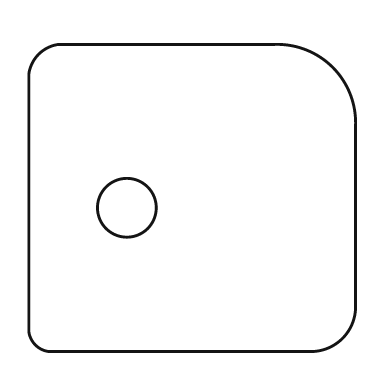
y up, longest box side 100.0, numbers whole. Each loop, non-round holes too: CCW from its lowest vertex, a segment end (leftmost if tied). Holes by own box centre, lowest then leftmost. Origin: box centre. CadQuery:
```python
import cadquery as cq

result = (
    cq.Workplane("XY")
    .moveTo(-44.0, -47.0)
    .lineTo(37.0, -47.0)
    .threePointArc((46.0, -43.0), (50.0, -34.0))
    .lineTo(50.0, 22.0)
    .threePointArc((43.0, 40.0), (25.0, 47.0))
    .lineTo(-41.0, 47.0)
    .threePointArc((-47.0, 44.0), (-50.0, 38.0))
    .lineTo(-50.0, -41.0)
    .threePointArc((-48.0, -45.0), (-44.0, -47.0))
    .close()
    .moveTo(-20.0, -3.0)
    .circle(9.0)
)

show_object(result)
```